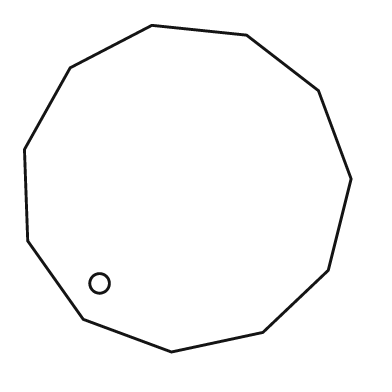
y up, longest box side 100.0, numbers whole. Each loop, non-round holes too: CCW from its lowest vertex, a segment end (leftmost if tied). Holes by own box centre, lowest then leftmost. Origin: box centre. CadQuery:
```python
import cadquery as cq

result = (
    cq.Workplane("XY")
    .moveTo(-5.0, -50.0)
    .lineTo(23.0, -44.0)
    .lineTo(43.0, -25.0)
    .lineTo(50.0, 3.0)
    .lineTo(40.0, 30.0)
    .lineTo(18.0, 47.0)
    .lineTo(-11.0, 50.0)
    .lineTo(-36.0, 37.0)
    .lineTo(-50.0, 12.0)
    .lineTo(-49.0, -16.0)
    .lineTo(-32.0, -40.0)
    .close()
    .moveTo(-27.0, -29.0)
    .circle(3.0)
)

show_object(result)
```